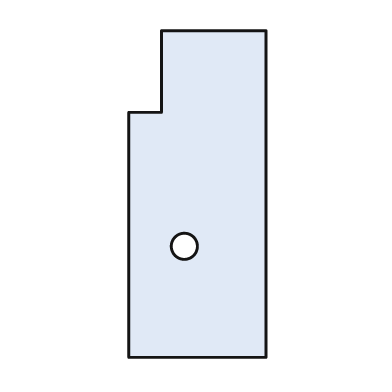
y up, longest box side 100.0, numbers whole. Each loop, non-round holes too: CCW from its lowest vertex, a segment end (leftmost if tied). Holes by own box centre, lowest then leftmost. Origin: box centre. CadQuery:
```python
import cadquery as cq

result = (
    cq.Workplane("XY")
    .moveTo(-21.0, -50.0)
    .lineTo(21.0, -50.0)
    .lineTo(21.0, 50.0)
    .lineTo(-11.0, 50.0)
    .lineTo(-11.0, 25.0)
    .lineTo(-21.0, 25.0)
    .close()
    .moveTo(-4.0, -16.0)
    .circle(4.0)
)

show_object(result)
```